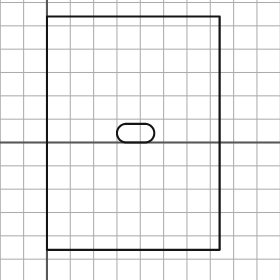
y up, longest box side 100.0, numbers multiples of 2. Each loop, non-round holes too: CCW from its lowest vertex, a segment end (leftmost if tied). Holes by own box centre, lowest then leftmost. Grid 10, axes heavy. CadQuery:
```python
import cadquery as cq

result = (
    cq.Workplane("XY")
    .moveTo(0.0, -46.0)
    .lineTo(74.0, -46.0)
    .lineTo(74.0, 54.0)
    .lineTo(0.0, 54.0)
    .close()
    .moveTo(34.0, 0.0)
    .lineTo(42.0, 0.0)
    .threePointArc((46.0, 4.0), (42.0, 8.0))
    .lineTo(34.0, 8.0)
    .threePointArc((30.0, 4.0), (34.0, 0.0))
    .close()
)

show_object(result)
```